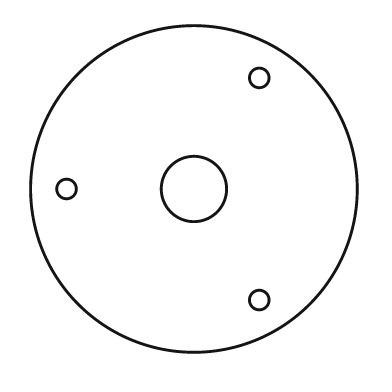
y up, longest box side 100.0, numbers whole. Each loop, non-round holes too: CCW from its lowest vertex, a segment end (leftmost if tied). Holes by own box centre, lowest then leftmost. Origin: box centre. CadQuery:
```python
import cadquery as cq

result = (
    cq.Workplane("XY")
    .moveTo(0.0, 0.0)
    .circle(50.0)
    .moveTo(20.0, -34.0)
    .circle(3.0)
    .moveTo(-39.0, 0.0)
    .circle(3.0)
    .moveTo(0.0, 0.0)
    .circle(10.0)
    .moveTo(20.0, 34.0)
    .circle(3.0)
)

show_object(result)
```